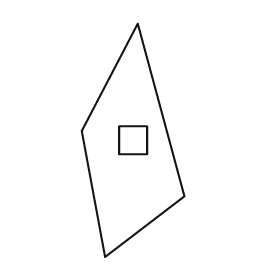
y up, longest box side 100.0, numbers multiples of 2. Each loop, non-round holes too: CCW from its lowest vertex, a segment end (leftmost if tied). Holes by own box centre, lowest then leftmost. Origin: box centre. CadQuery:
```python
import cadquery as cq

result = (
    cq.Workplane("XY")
    .moveTo(-12.0, -50.0)
    .lineTo(22.0, -24.0)
    .lineTo(2.0, 50.0)
    .lineTo(-22.0, 4.0)
    .close()
    .moveTo(-6.0, -6.0)
    .lineTo(6.0, -6.0)
    .lineTo(6.0, 6.0)
    .lineTo(-6.0, 6.0)
    .close()
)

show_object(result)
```